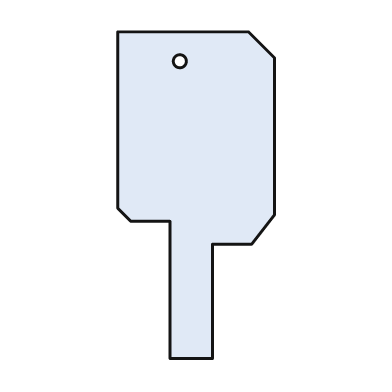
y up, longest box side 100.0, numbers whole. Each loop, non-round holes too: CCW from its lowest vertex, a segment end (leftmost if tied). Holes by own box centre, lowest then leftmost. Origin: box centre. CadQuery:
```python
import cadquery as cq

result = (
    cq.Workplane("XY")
    .moveTo(-8.0, -50.0)
    .lineTo(5.0, -50.0)
    .lineTo(5.0, -15.0)
    .lineTo(17.0, -15.0)
    .lineTo(24.0, -6.0)
    .lineTo(24.0, 42.0)
    .lineTo(16.0, 50.0)
    .lineTo(-24.0, 50.0)
    .lineTo(-24.0, -4.0)
    .lineTo(-20.0, -8.0)
    .lineTo(-8.0, -8.0)
    .close()
    .moveTo(-5.0, 41.0)
    .circle(2.0)
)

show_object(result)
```